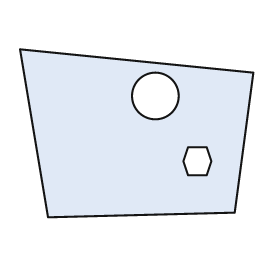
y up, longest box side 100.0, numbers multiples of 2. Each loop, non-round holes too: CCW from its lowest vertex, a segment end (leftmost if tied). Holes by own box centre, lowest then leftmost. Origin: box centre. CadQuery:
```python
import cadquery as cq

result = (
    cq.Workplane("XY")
    .moveTo(-38.0, -36.0)
    .lineTo(42.0, -34.0)
    .lineTo(50.0, 26.0)
    .lineTo(-50.0, 36.0)
    .close()
    .moveTo(22.0, -18.0)
    .lineTo(30.0, -18.0)
    .lineTo(32.0, -12.0)
    .lineTo(30.0, -6.0)
    .lineTo(22.0, -6.0)
    .lineTo(20.0, -12.0)
    .close()
    .moveTo(8.0, 16.0)
    .circle(10.0)
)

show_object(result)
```